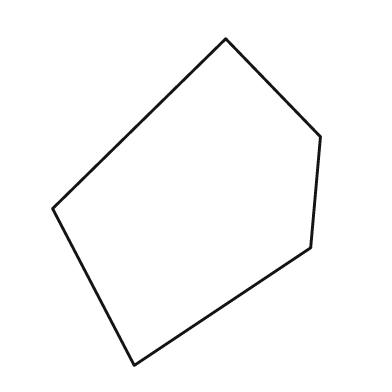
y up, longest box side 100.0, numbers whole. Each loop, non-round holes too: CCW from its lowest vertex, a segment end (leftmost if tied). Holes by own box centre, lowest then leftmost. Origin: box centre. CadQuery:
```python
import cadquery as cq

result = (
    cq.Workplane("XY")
    .moveTo(-16.0, -50.0)
    .lineTo(38.0, -14.0)
    .lineTo(41.0, 20.0)
    .lineTo(12.0, 50.0)
    .lineTo(-41.0, -2.0)
    .close()
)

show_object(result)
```